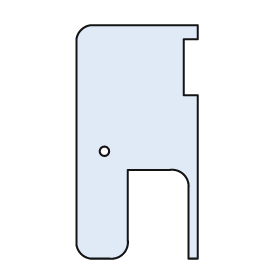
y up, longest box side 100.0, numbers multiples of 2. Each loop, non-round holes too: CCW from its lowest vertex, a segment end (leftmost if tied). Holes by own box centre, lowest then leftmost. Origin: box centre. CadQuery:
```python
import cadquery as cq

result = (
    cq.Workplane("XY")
    .moveTo(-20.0, -50.0)
    .lineTo(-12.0, -50.0)
    .threePointArc((-6.0, -48.0), (-4.0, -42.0))
    .lineTo(-4.0, -12.0)
    .lineTo(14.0, -12.0)
    .threePointArc((20.0, -14.0), (22.0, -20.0))
    .lineTo(22.0, -50.0)
    .lineTo(26.0, -50.0)
    .lineTo(26.0, 20.0)
    .lineTo(20.0, 20.0)
    .lineTo(20.0, 44.0)
    .lineTo(26.0, 44.0)
    .lineTo(26.0, 50.0)
    .lineTo(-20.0, 50.0)
    .threePointArc((-24.0, 48.0), (-26.0, 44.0))
    .lineTo(-26.0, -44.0)
    .threePointArc((-24.0, -48.0), (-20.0, -50.0))
    .close()
    .moveTo(-14.0, -4.0)
    .circle(2.0)
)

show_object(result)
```